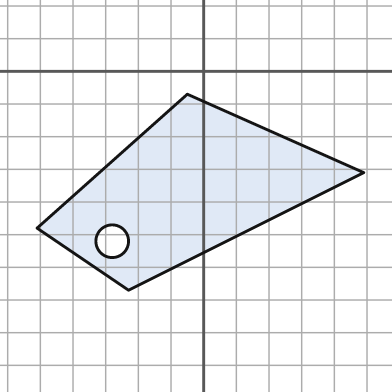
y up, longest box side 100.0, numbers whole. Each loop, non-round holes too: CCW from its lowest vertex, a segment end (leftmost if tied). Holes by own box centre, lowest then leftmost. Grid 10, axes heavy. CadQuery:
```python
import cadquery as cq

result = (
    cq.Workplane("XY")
    .moveTo(-23.0, -67.0)
    .lineTo(49.0, -31.0)
    .lineTo(-5.0, -7.0)
    .lineTo(-51.0, -48.0)
    .close()
    .moveTo(-28.0, -52.0)
    .circle(5.0)
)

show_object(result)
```